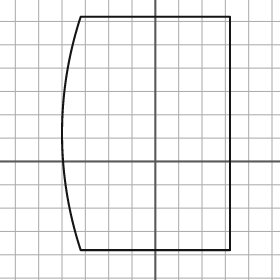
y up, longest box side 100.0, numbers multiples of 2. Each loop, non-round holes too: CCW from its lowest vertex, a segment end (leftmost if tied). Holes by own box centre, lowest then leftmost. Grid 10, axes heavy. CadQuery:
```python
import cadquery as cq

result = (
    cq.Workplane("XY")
    .moveTo(-32.0, -38.0)
    .lineTo(32.0, -38.0)
    .lineTo(32.0, 62.0)
    .lineTo(-32.0, 62.0)
    .threePointArc((-40.0, 12.0), (-32.0, -38.0))
    .close()
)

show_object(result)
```